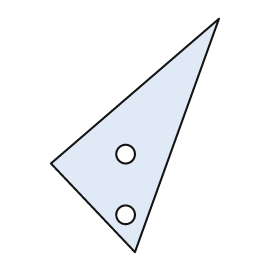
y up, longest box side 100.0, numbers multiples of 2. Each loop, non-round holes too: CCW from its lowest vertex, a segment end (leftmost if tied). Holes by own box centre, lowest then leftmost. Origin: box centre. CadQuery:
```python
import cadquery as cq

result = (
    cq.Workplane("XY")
    .moveTo(0.0, -50.0)
    .lineTo(36.0, 50.0)
    .lineTo(-36.0, -12.0)
    .close()
    .moveTo(-4.0, -34.0)
    .circle(4.0)
    .moveTo(-4.0, -8.0)
    .circle(4.0)
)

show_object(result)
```